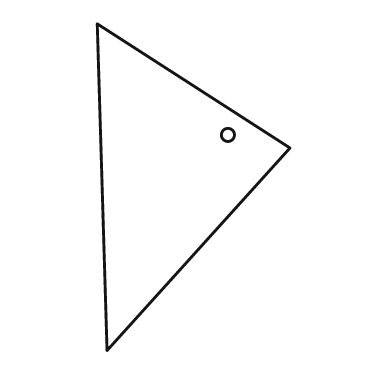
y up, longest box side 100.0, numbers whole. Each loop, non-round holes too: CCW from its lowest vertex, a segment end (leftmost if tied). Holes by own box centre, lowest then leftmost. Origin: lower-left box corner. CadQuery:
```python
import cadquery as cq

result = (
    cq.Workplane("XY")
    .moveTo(3.0, 0.0)
    .lineTo(59.0, 62.0)
    .lineTo(0.0, 100.0)
    .close()
    .moveTo(40.0, 66.0)
    .circle(2.0)
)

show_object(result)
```